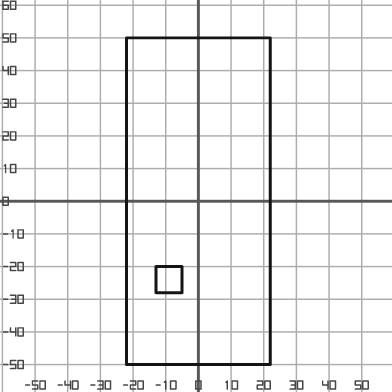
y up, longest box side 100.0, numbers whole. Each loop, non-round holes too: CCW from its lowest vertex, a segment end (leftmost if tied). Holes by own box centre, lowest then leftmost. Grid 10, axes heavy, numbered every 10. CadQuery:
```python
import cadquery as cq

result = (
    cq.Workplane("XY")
    .moveTo(-22.0, -50.0)
    .lineTo(22.0, -50.0)
    .lineTo(22.0, 50.0)
    .lineTo(-22.0, 50.0)
    .close()
    .moveTo(-13.0, -28.0)
    .lineTo(-5.0, -28.0)
    .lineTo(-5.0, -20.0)
    .lineTo(-13.0, -20.0)
    .close()
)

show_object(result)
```